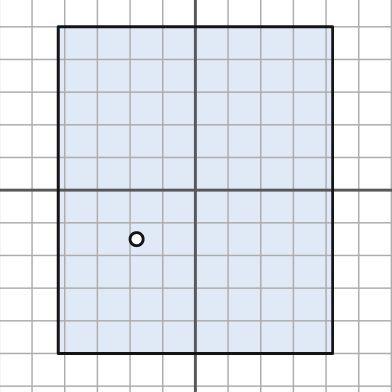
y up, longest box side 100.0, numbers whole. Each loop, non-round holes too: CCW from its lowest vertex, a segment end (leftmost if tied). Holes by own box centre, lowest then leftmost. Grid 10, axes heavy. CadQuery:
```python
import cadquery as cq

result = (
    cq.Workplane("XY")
    .moveTo(-42.0, -50.0)
    .lineTo(42.0, -50.0)
    .lineTo(42.0, 50.0)
    .lineTo(-42.0, 50.0)
    .close()
    .moveTo(-18.0, -15.0)
    .circle(2.0)
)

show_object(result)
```